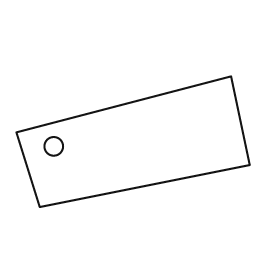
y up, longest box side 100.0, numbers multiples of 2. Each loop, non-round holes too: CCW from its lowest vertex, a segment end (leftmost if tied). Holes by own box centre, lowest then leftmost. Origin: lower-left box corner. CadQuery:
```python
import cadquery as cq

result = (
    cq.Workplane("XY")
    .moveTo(10.0, 0.0)
    .lineTo(100.0, 18.0)
    .lineTo(92.0, 56.0)
    .lineTo(0.0, 32.0)
    .close()
    .moveTo(16.0, 26.0)
    .circle(4.0)
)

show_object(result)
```